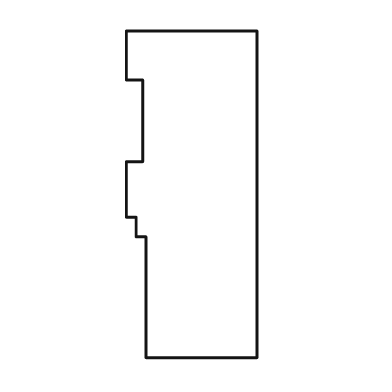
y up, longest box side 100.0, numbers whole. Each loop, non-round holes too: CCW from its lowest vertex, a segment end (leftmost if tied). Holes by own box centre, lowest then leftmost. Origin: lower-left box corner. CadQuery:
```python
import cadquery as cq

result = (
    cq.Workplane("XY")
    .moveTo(6.0, 0.0)
    .lineTo(40.0, 0.0)
    .lineTo(40.0, 100.0)
    .lineTo(0.0, 100.0)
    .lineTo(0.0, 85.0)
    .lineTo(5.0, 85.0)
    .lineTo(5.0, 60.0)
    .lineTo(0.0, 60.0)
    .lineTo(0.0, 43.0)
    .lineTo(3.0, 43.0)
    .lineTo(3.0, 37.0)
    .lineTo(6.0, 37.0)
    .close()
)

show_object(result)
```